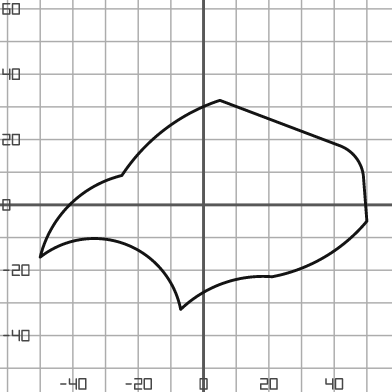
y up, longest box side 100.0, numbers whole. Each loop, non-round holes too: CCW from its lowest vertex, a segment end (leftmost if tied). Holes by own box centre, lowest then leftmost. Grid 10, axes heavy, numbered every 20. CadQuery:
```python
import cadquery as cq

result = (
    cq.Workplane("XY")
    .moveTo(-7.0, -32.0)
    .threePointArc((6.0, -24.0), (21.0, -22.0))
    .threePointArc((37.0, -16.0), (50.0, -5.0))
    .lineTo(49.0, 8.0)
    .threePointArc((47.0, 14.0), (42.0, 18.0))
    .lineTo(5.0, 32.0)
    .threePointArc((-12.0, 23.0), (-25.0, 9.0))
    .threePointArc((-41.0, 0.0), (-50.0, -16.0))
    .threePointArc((-24.0, -12.0), (-7.0, -32.0))
    .close()
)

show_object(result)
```